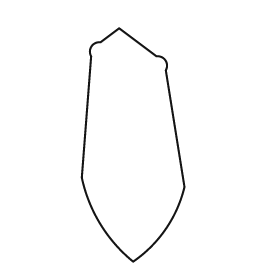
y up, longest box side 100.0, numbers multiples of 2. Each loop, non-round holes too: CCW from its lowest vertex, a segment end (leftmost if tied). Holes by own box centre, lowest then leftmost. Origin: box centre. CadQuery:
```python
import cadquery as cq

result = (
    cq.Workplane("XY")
    .moveTo(0.0, -50.0)
    .threePointArc((14.0, -36.0), (22.0, -18.0))
    .lineTo(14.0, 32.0)
    .threePointArc((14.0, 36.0), (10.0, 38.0))
    .lineTo(-6.0, 50.0)
    .lineTo(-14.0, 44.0)
    .threePointArc((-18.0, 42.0), (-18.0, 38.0))
    .lineTo(-22.0, -14.0)
    .threePointArc((-14.0, -34.0), (0.0, -50.0))
    .close()
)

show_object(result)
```